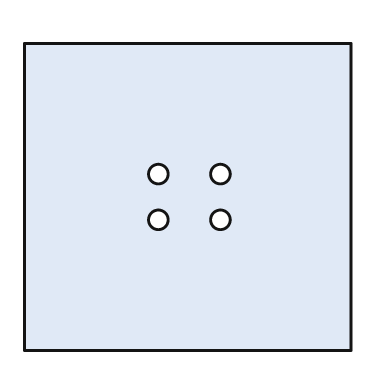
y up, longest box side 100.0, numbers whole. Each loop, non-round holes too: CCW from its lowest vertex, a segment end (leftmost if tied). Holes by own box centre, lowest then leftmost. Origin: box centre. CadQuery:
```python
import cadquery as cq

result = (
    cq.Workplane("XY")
    .moveTo(-50.0, -47.0)
    .lineTo(50.0, -47.0)
    .lineTo(50.0, 47.0)
    .lineTo(-50.0, 47.0)
    .close()
    .moveTo(-9.0, -7.0)
    .circle(3.0)
    .moveTo(10.0, -7.0)
    .circle(3.0)
    .moveTo(-9.0, 7.0)
    .circle(3.0)
    .moveTo(10.0, 7.0)
    .circle(3.0)
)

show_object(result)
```